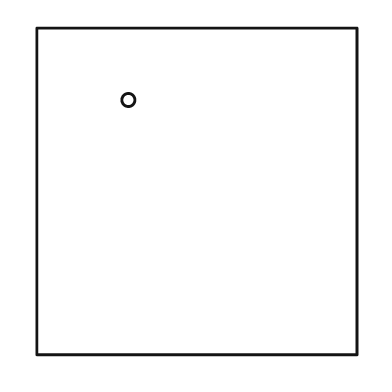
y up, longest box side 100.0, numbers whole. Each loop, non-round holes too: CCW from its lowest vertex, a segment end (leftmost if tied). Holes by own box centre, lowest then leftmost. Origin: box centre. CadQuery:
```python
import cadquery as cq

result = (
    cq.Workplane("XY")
    .moveTo(-49.0, -50.0)
    .lineTo(49.0, -50.0)
    .lineTo(49.0, 50.0)
    .lineTo(-49.0, 50.0)
    .close()
    .moveTo(-21.0, 28.0)
    .circle(2.0)
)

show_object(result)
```